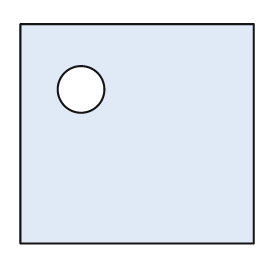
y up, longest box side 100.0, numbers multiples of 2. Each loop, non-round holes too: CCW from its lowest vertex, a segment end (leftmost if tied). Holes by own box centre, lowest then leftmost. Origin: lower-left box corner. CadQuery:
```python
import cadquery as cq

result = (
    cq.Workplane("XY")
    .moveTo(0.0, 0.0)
    .lineTo(100.0, 0.0)
    .lineTo(100.0, 94.0)
    .lineTo(0.0, 94.0)
    .close()
    .moveTo(26.0, 66.0)
    .circle(10.0)
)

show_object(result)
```